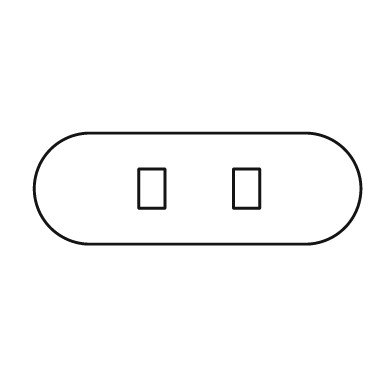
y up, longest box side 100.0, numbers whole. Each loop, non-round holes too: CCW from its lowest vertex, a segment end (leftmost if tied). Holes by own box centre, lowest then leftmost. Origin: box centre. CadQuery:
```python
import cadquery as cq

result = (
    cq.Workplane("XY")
    .moveTo(-33.0, -17.0)
    .lineTo(33.0, -17.0)
    .threePointArc((50.0, 0.0), (33.0, 17.0))
    .lineTo(-33.0, 17.0)
    .threePointArc((-50.0, 0.0), (-33.0, -17.0))
    .close()
    .moveTo(-18.0, -6.0)
    .lineTo(-10.0, -6.0)
    .lineTo(-10.0, 6.0)
    .lineTo(-18.0, 6.0)
    .close()
    .moveTo(11.0, -6.0)
    .lineTo(19.0, -6.0)
    .lineTo(19.0, 6.0)
    .lineTo(11.0, 6.0)
    .close()
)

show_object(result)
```